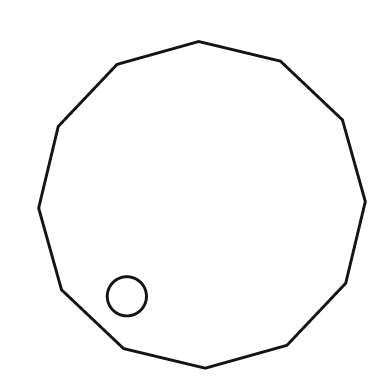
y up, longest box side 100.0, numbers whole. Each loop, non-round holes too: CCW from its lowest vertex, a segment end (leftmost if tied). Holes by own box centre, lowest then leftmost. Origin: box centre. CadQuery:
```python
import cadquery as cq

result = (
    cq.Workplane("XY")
    .moveTo(1.0, -50.0)
    .lineTo(26.0, -43.0)
    .lineTo(44.0, -24.0)
    .lineTo(50.0, 1.0)
    .lineTo(43.0, 26.0)
    .lineTo(24.0, 44.0)
    .lineTo(-1.0, 50.0)
    .lineTo(-26.0, 43.0)
    .lineTo(-44.0, 24.0)
    .lineTo(-50.0, -1.0)
    .lineTo(-43.0, -26.0)
    .lineTo(-24.0, -44.0)
    .close()
    .moveTo(-23.0, -28.0)
    .circle(6.0)
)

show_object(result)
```